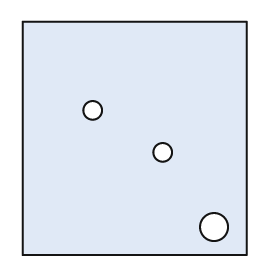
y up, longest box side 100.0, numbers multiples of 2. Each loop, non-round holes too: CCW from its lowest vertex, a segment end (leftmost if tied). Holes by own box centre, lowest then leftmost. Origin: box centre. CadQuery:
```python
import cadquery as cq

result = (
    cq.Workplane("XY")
    .moveTo(-48.0, -50.0)
    .lineTo(48.0, -50.0)
    .lineTo(48.0, 50.0)
    .lineTo(-48.0, 50.0)
    .close()
    .moveTo(34.0, -38.0)
    .circle(6.0)
    .moveTo(12.0, -6.0)
    .circle(4.0)
    .moveTo(-18.0, 12.0)
    .circle(4.0)
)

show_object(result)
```